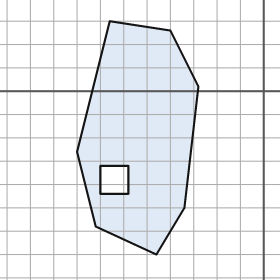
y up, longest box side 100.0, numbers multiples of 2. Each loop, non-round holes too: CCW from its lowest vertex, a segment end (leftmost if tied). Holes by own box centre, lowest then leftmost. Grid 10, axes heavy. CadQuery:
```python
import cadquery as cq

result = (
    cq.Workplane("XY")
    .moveTo(-46.0, -70.0)
    .lineTo(-34.0, -50.0)
    .lineTo(-28.0, 2.0)
    .lineTo(-40.0, 26.0)
    .lineTo(-66.0, 30.0)
    .lineTo(-80.0, -26.0)
    .lineTo(-72.0, -58.0)
    .close()
    .moveTo(-70.0, -44.0)
    .lineTo(-58.0, -44.0)
    .lineTo(-58.0, -32.0)
    .lineTo(-70.0, -32.0)
    .close()
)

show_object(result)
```